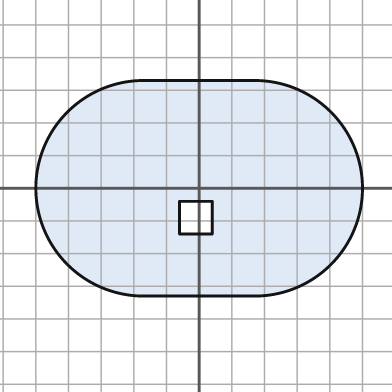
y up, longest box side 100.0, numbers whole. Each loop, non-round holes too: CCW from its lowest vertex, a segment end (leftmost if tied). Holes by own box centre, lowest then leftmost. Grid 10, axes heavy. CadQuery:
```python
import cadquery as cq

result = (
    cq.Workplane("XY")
    .moveTo(-17.0, -33.0)
    .lineTo(17.0, -33.0)
    .threePointArc((50.0, 0.0), (17.0, 33.0))
    .lineTo(-17.0, 33.0)
    .threePointArc((-50.0, 0.0), (-17.0, -33.0))
    .close()
    .moveTo(-6.0, -14.0)
    .lineTo(4.0, -14.0)
    .lineTo(4.0, -4.0)
    .lineTo(-6.0, -4.0)
    .close()
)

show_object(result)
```